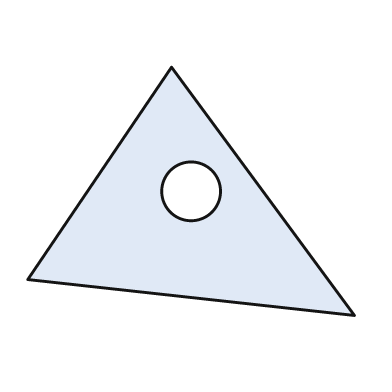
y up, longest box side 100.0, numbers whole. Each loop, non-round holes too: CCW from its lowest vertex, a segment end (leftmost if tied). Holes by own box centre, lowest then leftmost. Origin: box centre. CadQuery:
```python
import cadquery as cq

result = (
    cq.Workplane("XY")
    .moveTo(50.0, -38.0)
    .lineTo(-6.0, 38.0)
    .lineTo(-50.0, -27.0)
    .close()
    .moveTo(0.0, 0.0)
    .circle(9.0)
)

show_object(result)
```